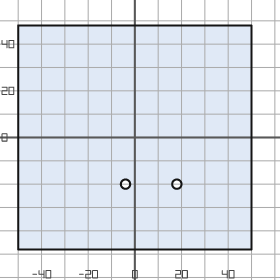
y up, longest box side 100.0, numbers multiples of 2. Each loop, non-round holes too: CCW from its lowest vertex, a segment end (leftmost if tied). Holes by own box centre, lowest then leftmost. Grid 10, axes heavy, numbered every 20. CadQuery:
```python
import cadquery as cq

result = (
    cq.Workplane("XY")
    .moveTo(-50.0, -48.0)
    .lineTo(50.0, -48.0)
    .lineTo(50.0, 48.0)
    .lineTo(-50.0, 48.0)
    .close()
    .moveTo(-4.0, -20.0)
    .circle(2.0)
    .moveTo(18.0, -20.0)
    .circle(2.0)
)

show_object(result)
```